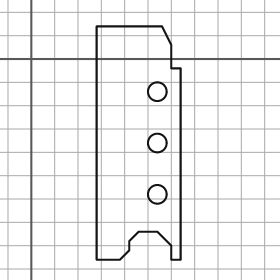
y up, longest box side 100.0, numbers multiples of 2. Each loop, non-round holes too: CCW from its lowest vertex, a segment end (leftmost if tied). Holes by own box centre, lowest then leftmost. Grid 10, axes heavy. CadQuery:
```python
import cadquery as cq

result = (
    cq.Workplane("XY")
    .moveTo(28.0, -86.0)
    .lineTo(38.0, -86.0)
    .lineTo(42.0, -82.0)
    .lineTo(42.0, -78.0)
    .lineTo(46.0, -74.0)
    .lineTo(54.0, -74.0)
    .lineTo(60.0, -80.0)
    .lineTo(60.0, -86.0)
    .lineTo(64.0, -86.0)
    .lineTo(64.0, -4.0)
    .lineTo(60.0, -4.0)
    .lineTo(60.0, 6.0)
    .lineTo(56.0, 14.0)
    .lineTo(28.0, 14.0)
    .close()
    .moveTo(54.0, -58.0)
    .circle(4.0)
    .moveTo(54.0, -36.0)
    .circle(4.0)
    .moveTo(54.0, -14.0)
    .circle(4.0)
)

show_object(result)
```